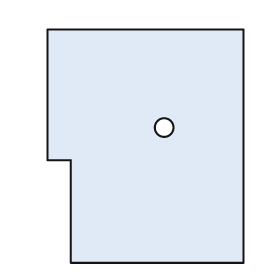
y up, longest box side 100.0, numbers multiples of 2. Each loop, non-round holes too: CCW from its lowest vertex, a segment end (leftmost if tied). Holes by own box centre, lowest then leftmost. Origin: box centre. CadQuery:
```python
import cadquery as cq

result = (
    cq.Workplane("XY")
    .moveTo(-32.0, -50.0)
    .lineTo(42.0, -50.0)
    .lineTo(42.0, 50.0)
    .lineTo(-42.0, 50.0)
    .lineTo(-42.0, -6.0)
    .lineTo(-32.0, -6.0)
    .close()
    .moveTo(8.0, 8.0)
    .circle(4.0)
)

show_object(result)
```